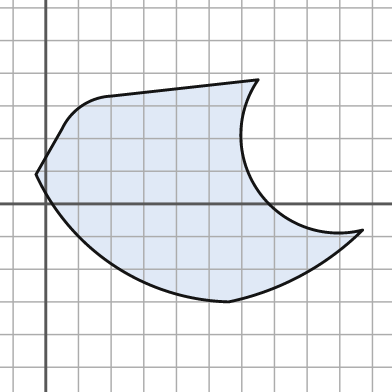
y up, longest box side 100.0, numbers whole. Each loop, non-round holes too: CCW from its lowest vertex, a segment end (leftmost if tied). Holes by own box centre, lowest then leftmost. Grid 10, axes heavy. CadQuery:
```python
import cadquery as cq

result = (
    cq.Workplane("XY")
    .moveTo(56.0, -30.0)
    .threePointArc((78.0, -22.0), (97.0, -8.0))
    .threePointArc((65.0, 4.0), (65.0, 38.0))
    .lineTo(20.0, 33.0)
    .threePointArc((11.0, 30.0), (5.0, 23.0))
    .lineTo(-3.0, 9.0)
    .threePointArc((21.0, -19.0), (56.0, -30.0))
    .close()
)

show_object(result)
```